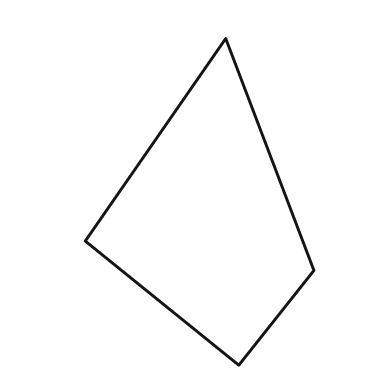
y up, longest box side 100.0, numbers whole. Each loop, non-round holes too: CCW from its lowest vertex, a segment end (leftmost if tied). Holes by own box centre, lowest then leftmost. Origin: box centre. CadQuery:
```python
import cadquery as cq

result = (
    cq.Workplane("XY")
    .moveTo(12.0, -50.0)
    .lineTo(35.0, -21.0)
    .lineTo(8.0, 50.0)
    .lineTo(-35.0, -12.0)
    .close()
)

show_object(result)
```